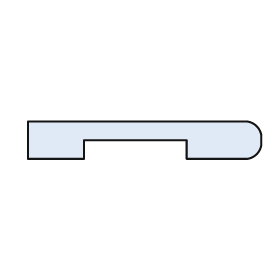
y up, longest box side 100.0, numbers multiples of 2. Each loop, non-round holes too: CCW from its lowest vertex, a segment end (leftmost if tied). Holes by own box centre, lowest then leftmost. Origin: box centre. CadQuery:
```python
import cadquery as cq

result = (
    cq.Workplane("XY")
    .moveTo(-50.0, -8.0)
    .lineTo(-26.0, -8.0)
    .lineTo(-26.0, 0.0)
    .lineTo(18.0, 0.0)
    .lineTo(18.0, -8.0)
    .lineTo(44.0, -8.0)
    .threePointArc((48.0, -6.0), (50.0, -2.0))
    .lineTo(50.0, 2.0)
    .threePointArc((48.0, 6.0), (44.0, 8.0))
    .lineTo(-50.0, 8.0)
    .close()
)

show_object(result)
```